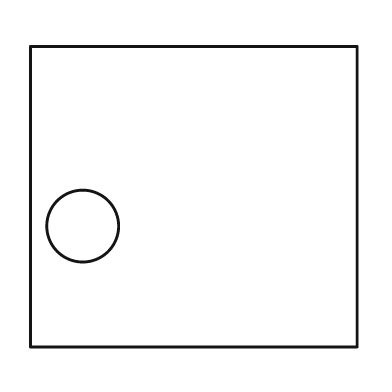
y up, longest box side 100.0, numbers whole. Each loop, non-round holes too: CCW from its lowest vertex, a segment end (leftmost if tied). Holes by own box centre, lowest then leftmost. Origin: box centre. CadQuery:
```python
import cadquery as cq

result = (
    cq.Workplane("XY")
    .moveTo(-50.0, -46.0)
    .lineTo(50.0, -46.0)
    .lineTo(50.0, 46.0)
    .lineTo(-50.0, 46.0)
    .close()
    .moveTo(-34.0, -9.0)
    .circle(11.0)
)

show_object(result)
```